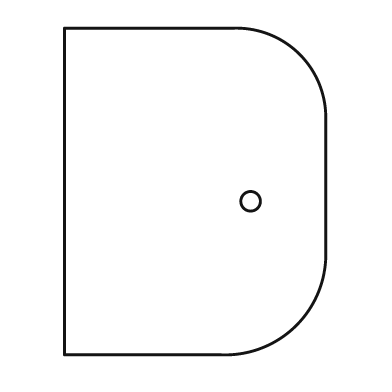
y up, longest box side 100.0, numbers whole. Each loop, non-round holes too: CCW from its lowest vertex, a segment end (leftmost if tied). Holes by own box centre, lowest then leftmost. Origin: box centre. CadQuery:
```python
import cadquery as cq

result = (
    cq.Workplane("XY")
    .moveTo(-40.0, -50.0)
    .lineTo(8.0, -50.0)
    .threePointArc((31.0, -41.0), (40.0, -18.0))
    .lineTo(40.0, 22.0)
    .threePointArc((32.0, 42.0), (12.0, 50.0))
    .lineTo(-40.0, 50.0)
    .close()
    .moveTo(17.0, -3.0)
    .circle(3.0)
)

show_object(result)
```